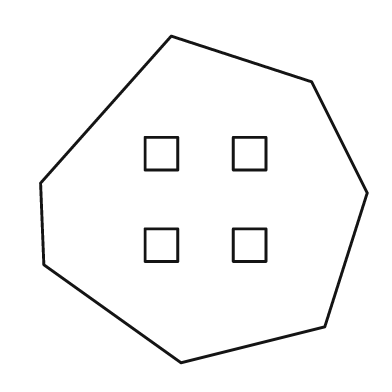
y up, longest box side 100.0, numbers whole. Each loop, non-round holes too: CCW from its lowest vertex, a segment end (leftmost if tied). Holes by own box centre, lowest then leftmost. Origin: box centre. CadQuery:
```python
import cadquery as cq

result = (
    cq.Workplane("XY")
    .moveTo(-7.0, -50.0)
    .lineTo(37.0, -39.0)
    .lineTo(50.0, 2.0)
    .lineTo(33.0, 36.0)
    .lineTo(-10.0, 50.0)
    .lineTo(-50.0, 5.0)
    .lineTo(-49.0, -20.0)
    .close()
    .moveTo(-18.0, -19.0)
    .lineTo(-8.0, -19.0)
    .lineTo(-8.0, -9.0)
    .lineTo(-18.0, -9.0)
    .close()
    .moveTo(9.0, -19.0)
    .lineTo(19.0, -19.0)
    .lineTo(19.0, -9.0)
    .lineTo(9.0, -9.0)
    .close()
    .moveTo(-18.0, 9.0)
    .lineTo(-8.0, 9.0)
    .lineTo(-8.0, 19.0)
    .lineTo(-18.0, 19.0)
    .close()
    .moveTo(9.0, 9.0)
    .lineTo(19.0, 9.0)
    .lineTo(19.0, 19.0)
    .lineTo(9.0, 19.0)
    .close()
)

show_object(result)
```